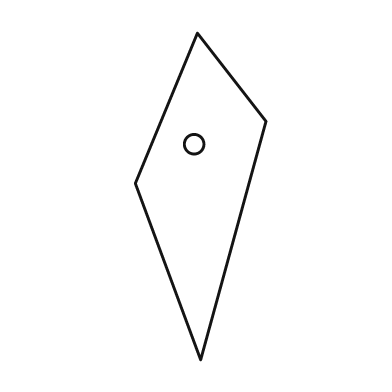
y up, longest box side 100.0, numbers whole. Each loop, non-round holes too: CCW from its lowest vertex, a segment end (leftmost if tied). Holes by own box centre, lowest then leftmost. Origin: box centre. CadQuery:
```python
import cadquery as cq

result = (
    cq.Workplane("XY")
    .moveTo(0.0, -50.0)
    .lineTo(20.0, 23.0)
    .lineTo(-1.0, 50.0)
    .lineTo(-20.0, 4.0)
    .close()
    .moveTo(-2.0, 16.0)
    .circle(3.0)
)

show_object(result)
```